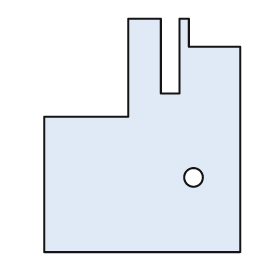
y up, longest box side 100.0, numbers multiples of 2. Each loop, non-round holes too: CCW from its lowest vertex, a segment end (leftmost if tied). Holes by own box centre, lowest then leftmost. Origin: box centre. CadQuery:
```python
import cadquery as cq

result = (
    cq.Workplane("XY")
    .moveTo(-42.0, -50.0)
    .lineTo(42.0, -50.0)
    .lineTo(42.0, 38.0)
    .lineTo(20.0, 38.0)
    .lineTo(20.0, 50.0)
    .lineTo(16.0, 50.0)
    .lineTo(16.0, 18.0)
    .lineTo(8.0, 18.0)
    .lineTo(8.0, 50.0)
    .lineTo(-6.0, 50.0)
    .lineTo(-6.0, 8.0)
    .lineTo(-42.0, 8.0)
    .close()
    .moveTo(22.0, -18.0)
    .circle(4.0)
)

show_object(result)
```